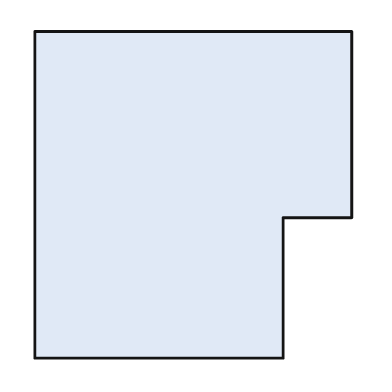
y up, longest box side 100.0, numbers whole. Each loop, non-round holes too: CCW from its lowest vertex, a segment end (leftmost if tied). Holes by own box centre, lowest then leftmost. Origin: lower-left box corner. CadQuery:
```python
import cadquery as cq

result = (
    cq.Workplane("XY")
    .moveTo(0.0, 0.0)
    .lineTo(76.0, 0.0)
    .lineTo(76.0, 43.0)
    .lineTo(97.0, 43.0)
    .lineTo(97.0, 100.0)
    .lineTo(0.0, 100.0)
    .close()
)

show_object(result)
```